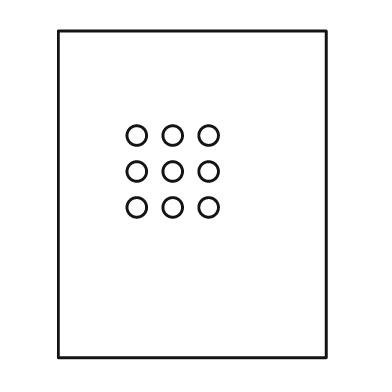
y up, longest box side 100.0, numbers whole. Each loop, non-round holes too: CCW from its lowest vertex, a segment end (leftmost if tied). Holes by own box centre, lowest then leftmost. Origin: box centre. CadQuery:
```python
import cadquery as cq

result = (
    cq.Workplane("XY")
    .moveTo(-41.0, -50.0)
    .lineTo(41.0, -50.0)
    .lineTo(41.0, 50.0)
    .lineTo(-41.0, 50.0)
    .close()
    .moveTo(-17.0, -4.0)
    .circle(3.0)
    .moveTo(-6.0, -4.0)
    .circle(3.0)
    .moveTo(5.0, -4.0)
    .circle(3.0)
    .moveTo(-17.0, 7.0)
    .circle(3.0)
    .moveTo(-6.0, 7.0)
    .circle(3.0)
    .moveTo(5.0, 7.0)
    .circle(3.0)
    .moveTo(-17.0, 18.0)
    .circle(3.0)
    .moveTo(-6.0, 18.0)
    .circle(3.0)
    .moveTo(5.0, 18.0)
    .circle(3.0)
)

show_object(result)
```